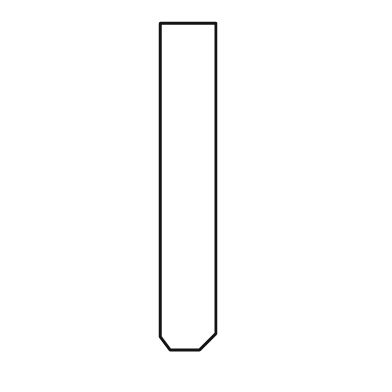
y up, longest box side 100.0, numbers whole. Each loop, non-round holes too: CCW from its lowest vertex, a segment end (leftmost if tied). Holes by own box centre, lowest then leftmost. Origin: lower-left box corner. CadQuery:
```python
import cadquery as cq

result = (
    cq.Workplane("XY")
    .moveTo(3.0, 0.0)
    .lineTo(12.0, 0.0)
    .lineTo(17.0, 5.0)
    .lineTo(17.0, 100.0)
    .lineTo(0.0, 100.0)
    .lineTo(0.0, 4.0)
    .close()
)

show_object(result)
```